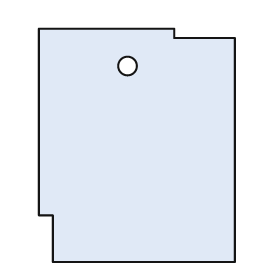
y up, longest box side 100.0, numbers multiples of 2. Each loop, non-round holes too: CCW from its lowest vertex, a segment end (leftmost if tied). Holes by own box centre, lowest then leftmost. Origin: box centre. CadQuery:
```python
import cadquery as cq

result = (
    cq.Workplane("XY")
    .moveTo(-36.0, -50.0)
    .lineTo(42.0, -50.0)
    .lineTo(42.0, 46.0)
    .lineTo(16.0, 46.0)
    .lineTo(16.0, 50.0)
    .lineTo(-42.0, 50.0)
    .lineTo(-42.0, -30.0)
    .lineTo(-36.0, -30.0)
    .close()
    .moveTo(-4.0, 34.0)
    .circle(4.0)
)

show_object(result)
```